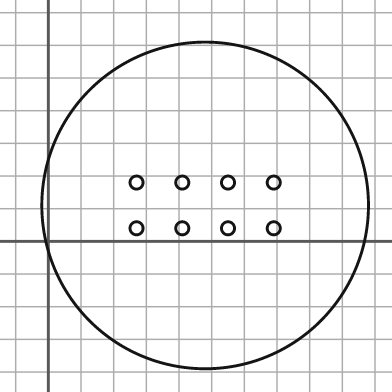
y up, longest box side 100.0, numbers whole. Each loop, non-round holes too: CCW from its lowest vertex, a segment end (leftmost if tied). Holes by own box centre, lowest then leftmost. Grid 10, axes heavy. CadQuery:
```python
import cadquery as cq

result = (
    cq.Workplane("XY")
    .moveTo(48.0, 11.0)
    .circle(50.0)
    .moveTo(27.0, 4.0)
    .circle(2.0)
    .moveTo(41.0, 4.0)
    .circle(2.0)
    .moveTo(55.0, 4.0)
    .circle(2.0)
    .moveTo(69.0, 4.0)
    .circle(2.0)
    .moveTo(27.0, 18.0)
    .circle(2.0)
    .moveTo(41.0, 18.0)
    .circle(2.0)
    .moveTo(55.0, 18.0)
    .circle(2.0)
    .moveTo(69.0, 18.0)
    .circle(2.0)
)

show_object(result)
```